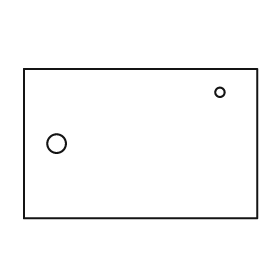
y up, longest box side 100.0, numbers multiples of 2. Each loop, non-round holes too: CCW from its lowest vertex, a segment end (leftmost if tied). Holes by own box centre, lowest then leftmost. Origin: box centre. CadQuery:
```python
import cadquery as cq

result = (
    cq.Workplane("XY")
    .moveTo(-50.0, -32.0)
    .lineTo(50.0, -32.0)
    .lineTo(50.0, 32.0)
    .lineTo(-50.0, 32.0)
    .close()
    .moveTo(-36.0, 0.0)
    .circle(4.0)
    .moveTo(34.0, 22.0)
    .circle(2.0)
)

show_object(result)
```